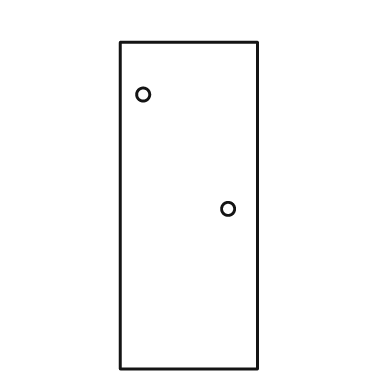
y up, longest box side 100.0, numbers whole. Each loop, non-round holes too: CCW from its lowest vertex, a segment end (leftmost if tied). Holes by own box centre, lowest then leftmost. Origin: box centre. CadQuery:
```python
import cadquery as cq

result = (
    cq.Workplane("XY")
    .moveTo(-21.0, -50.0)
    .lineTo(21.0, -50.0)
    .lineTo(21.0, 50.0)
    .lineTo(-21.0, 50.0)
    .close()
    .moveTo(12.0, -1.0)
    .circle(2.0)
    .moveTo(-14.0, 34.0)
    .circle(2.0)
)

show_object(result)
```